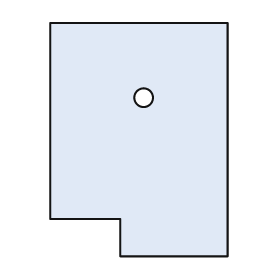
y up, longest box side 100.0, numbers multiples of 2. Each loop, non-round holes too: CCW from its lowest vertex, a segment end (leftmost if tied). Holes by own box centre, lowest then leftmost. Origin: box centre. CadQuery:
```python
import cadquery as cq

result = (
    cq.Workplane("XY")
    .moveTo(-8.0, -50.0)
    .lineTo(38.0, -50.0)
    .lineTo(38.0, 50.0)
    .lineTo(-38.0, 50.0)
    .lineTo(-38.0, -34.0)
    .lineTo(-8.0, -34.0)
    .close()
    .moveTo(2.0, 18.0)
    .circle(4.0)
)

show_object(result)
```